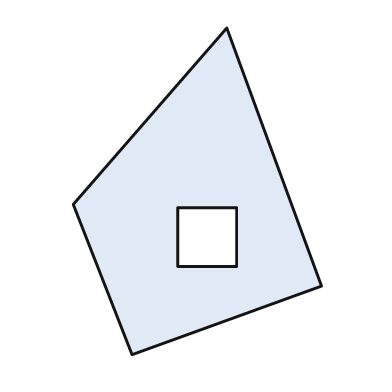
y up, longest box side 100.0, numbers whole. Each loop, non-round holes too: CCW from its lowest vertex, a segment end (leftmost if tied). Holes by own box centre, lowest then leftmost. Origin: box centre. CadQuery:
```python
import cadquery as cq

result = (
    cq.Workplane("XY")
    .moveTo(-20.0, -50.0)
    .lineTo(38.0, -29.0)
    .lineTo(9.0, 50.0)
    .lineTo(-38.0, -4.0)
    .close()
    .moveTo(-6.0, -23.0)
    .lineTo(12.0, -23.0)
    .lineTo(12.0, -5.0)
    .lineTo(-6.0, -5.0)
    .close()
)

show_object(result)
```